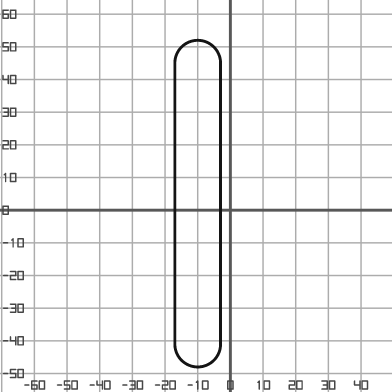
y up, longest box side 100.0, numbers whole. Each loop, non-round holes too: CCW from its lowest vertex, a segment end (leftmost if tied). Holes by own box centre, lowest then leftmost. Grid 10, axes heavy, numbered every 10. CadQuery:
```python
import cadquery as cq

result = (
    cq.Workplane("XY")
    .moveTo(-17.0, -41.0)
    .threePointArc((-10.0, -48.0), (-3.0, -41.0))
    .lineTo(-3.0, 45.0)
    .threePointArc((-10.0, 52.0), (-17.0, 45.0))
    .close()
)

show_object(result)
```